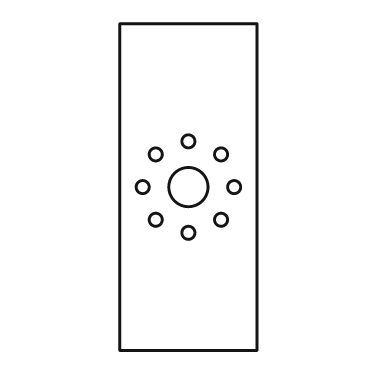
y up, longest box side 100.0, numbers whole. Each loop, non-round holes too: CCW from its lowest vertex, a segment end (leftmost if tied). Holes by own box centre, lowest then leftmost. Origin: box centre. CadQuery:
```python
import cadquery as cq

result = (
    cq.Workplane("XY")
    .moveTo(-21.0, -50.0)
    .lineTo(21.0, -50.0)
    .lineTo(21.0, 50.0)
    .lineTo(-21.0, 50.0)
    .close()
    .moveTo(0.0, -14.0)
    .circle(2.0)
    .moveTo(-10.0, -10.0)
    .circle(2.0)
    .moveTo(10.0, -10.0)
    .circle(2.0)
    .moveTo(-14.0, 0.0)
    .circle(2.0)
    .moveTo(0.0, 0.0)
    .circle(6.0)
    .moveTo(14.0, 0.0)
    .circle(2.0)
    .moveTo(-10.0, 10.0)
    .circle(2.0)
    .moveTo(10.0, 10.0)
    .circle(2.0)
    .moveTo(0.0, 14.0)
    .circle(2.0)
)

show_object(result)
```